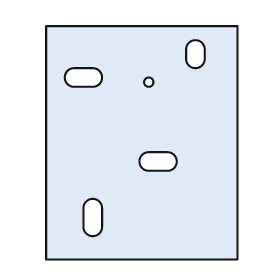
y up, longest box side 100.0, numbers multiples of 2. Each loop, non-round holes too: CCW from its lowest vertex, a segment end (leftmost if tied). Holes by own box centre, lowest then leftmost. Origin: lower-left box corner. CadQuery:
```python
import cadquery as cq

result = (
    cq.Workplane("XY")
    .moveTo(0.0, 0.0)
    .lineTo(82.0, 0.0)
    .lineTo(82.0, 100.0)
    .lineTo(0.0, 100.0)
    .close()
    .moveTo(16.0, 14.0)
    .threePointArc((20.0, 10.0), (24.0, 14.0))
    .lineTo(24.0, 22.0)
    .threePointArc((20.0, 26.0), (16.0, 22.0))
    .close()
    .moveTo(44.0, 38.0)
    .lineTo(52.0, 38.0)
    .threePointArc((56.0, 42.0), (52.0, 46.0))
    .lineTo(44.0, 46.0)
    .threePointArc((40.0, 42.0), (44.0, 38.0))
    .close()
    .moveTo(44.0, 76.0)
    .circle(2.0)
    .moveTo(12.0, 74.0)
    .lineTo(20.0, 74.0)
    .threePointArc((24.0, 78.0), (20.0, 82.0))
    .lineTo(12.0, 82.0)
    .threePointArc((8.0, 78.0), (12.0, 74.0))
    .close()
    .moveTo(60.0, 86.0)
    .threePointArc((64.0, 82.0), (68.0, 86.0))
    .lineTo(68.0, 90.0)
    .threePointArc((64.0, 94.0), (60.0, 90.0))
    .close()
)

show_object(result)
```